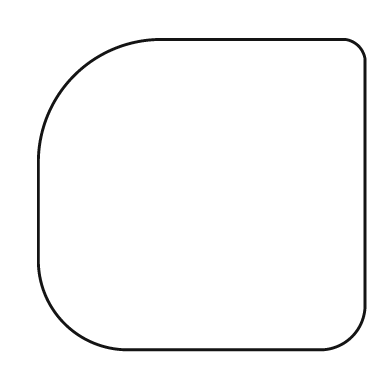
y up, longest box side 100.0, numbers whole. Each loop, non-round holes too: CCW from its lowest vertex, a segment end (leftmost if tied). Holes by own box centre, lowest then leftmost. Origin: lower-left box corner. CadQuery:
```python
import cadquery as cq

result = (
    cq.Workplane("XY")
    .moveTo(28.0, 0.0)
    .lineTo(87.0, 0.0)
    .threePointArc((96.0, 4.0), (100.0, 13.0))
    .lineTo(100.0, 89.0)
    .threePointArc((98.0, 93.0), (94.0, 95.0))
    .lineTo(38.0, 95.0)
    .threePointArc((11.0, 84.0), (0.0, 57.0))
    .lineTo(0.0, 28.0)
    .threePointArc((8.0, 8.0), (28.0, 0.0))
    .close()
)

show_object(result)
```